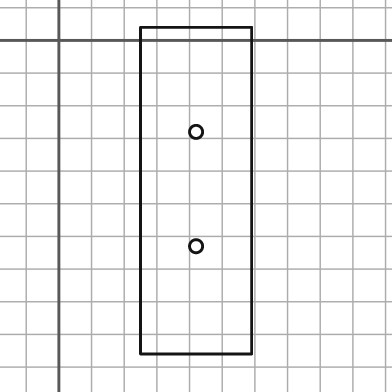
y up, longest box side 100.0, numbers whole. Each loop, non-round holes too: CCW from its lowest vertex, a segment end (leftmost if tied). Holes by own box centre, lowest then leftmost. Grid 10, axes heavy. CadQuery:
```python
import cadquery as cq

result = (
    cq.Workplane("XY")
    .moveTo(25.0, -96.0)
    .lineTo(59.0, -96.0)
    .lineTo(59.0, 4.0)
    .lineTo(25.0, 4.0)
    .close()
    .moveTo(42.0, -63.0)
    .circle(2.0)
    .moveTo(42.0, -28.0)
    .circle(2.0)
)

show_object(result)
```